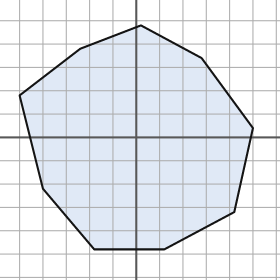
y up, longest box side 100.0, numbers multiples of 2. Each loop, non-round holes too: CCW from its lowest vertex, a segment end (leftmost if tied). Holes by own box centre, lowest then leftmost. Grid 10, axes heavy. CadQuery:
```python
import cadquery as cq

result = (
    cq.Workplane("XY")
    .moveTo(-18.0, -48.0)
    .lineTo(12.0, -48.0)
    .lineTo(42.0, -32.0)
    .lineTo(50.0, 4.0)
    .lineTo(28.0, 34.0)
    .lineTo(2.0, 48.0)
    .lineTo(-24.0, 38.0)
    .lineTo(-50.0, 18.0)
    .lineTo(-40.0, -22.0)
    .close()
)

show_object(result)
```